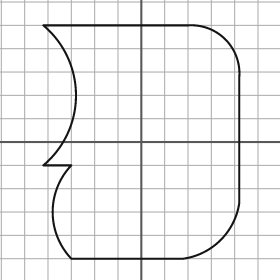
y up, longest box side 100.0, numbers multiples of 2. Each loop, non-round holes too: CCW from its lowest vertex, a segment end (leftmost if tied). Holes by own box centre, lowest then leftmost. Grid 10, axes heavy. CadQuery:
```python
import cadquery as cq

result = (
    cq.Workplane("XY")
    .moveTo(-30.0, -50.0)
    .lineTo(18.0, -50.0)
    .threePointArc((34.0, -42.0), (42.0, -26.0))
    .lineTo(42.0, 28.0)
    .threePointArc((36.0, 44.0), (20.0, 50.0))
    .lineTo(-42.0, 50.0)
    .threePointArc((-28.0, 20.0), (-42.0, -10.0))
    .lineTo(-30.0, -10.0)
    .threePointArc((-38.0, -30.0), (-30.0, -50.0))
    .close()
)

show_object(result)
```